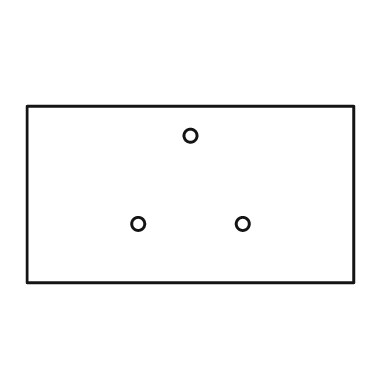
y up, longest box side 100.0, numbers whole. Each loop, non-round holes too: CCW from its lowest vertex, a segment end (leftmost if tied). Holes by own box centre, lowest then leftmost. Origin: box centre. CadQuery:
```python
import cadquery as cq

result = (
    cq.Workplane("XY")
    .moveTo(-50.0, -27.0)
    .lineTo(50.0, -27.0)
    .lineTo(50.0, 27.0)
    .lineTo(-50.0, 27.0)
    .close()
    .moveTo(-16.0, -9.0)
    .circle(2.0)
    .moveTo(16.0, -9.0)
    .circle(2.0)
    .moveTo(0.0, 18.0)
    .circle(2.0)
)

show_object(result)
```